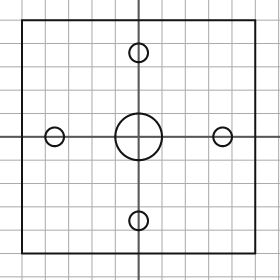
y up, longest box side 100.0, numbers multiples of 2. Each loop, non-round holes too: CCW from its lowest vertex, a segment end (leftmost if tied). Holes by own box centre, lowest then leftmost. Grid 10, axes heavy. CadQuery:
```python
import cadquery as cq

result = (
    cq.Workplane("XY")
    .moveTo(-50.0, -50.0)
    .lineTo(50.0, -50.0)
    .lineTo(50.0, 50.0)
    .lineTo(-50.0, 50.0)
    .close()
    .moveTo(0.0, -36.0)
    .circle(4.0)
    .moveTo(-36.0, 0.0)
    .circle(4.0)
    .moveTo(0.0, 0.0)
    .circle(10.0)
    .moveTo(36.0, 0.0)
    .circle(4.0)
    .moveTo(0.0, 36.0)
    .circle(4.0)
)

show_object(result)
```